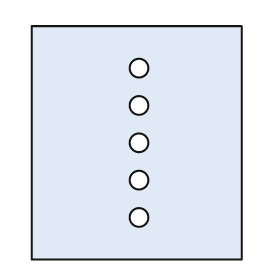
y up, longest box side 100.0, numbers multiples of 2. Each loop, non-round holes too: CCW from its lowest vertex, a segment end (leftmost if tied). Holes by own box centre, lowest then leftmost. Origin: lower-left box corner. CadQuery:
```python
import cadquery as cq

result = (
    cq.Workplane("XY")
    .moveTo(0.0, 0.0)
    .lineTo(90.0, 0.0)
    .lineTo(90.0, 100.0)
    .lineTo(0.0, 100.0)
    .close()
    .moveTo(46.0, 18.0)
    .circle(4.0)
    .moveTo(46.0, 34.0)
    .circle(4.0)
    .moveTo(46.0, 50.0)
    .circle(4.0)
    .moveTo(46.0, 66.0)
    .circle(4.0)
    .moveTo(46.0, 82.0)
    .circle(4.0)
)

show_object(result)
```